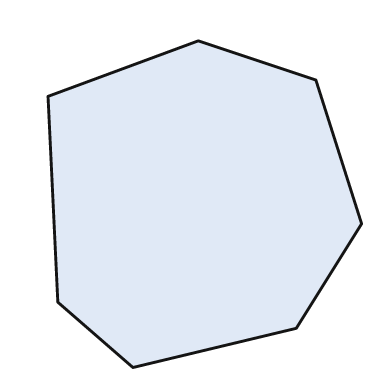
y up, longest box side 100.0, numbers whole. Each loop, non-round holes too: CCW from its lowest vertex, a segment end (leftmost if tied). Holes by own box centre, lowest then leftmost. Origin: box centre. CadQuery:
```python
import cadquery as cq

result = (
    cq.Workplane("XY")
    .moveTo(-22.0, -50.0)
    .lineTo(28.0, -38.0)
    .lineTo(48.0, -6.0)
    .lineTo(34.0, 38.0)
    .lineTo(-2.0, 50.0)
    .lineTo(-48.0, 33.0)
    .lineTo(-45.0, -30.0)
    .close()
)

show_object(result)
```